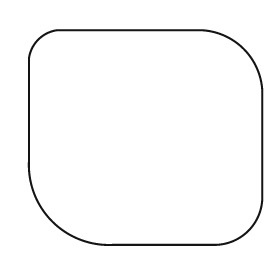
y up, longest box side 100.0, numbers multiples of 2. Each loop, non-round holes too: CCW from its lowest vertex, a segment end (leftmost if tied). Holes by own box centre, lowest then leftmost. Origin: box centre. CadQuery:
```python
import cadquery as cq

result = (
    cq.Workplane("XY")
    .moveTo(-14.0, -46.0)
    .lineTo(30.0, -46.0)
    .threePointArc((44.0, -40.0), (50.0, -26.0))
    .lineTo(50.0, 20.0)
    .threePointArc((42.0, 38.0), (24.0, 46.0))
    .lineTo(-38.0, 46.0)
    .threePointArc((-46.0, 42.0), (-50.0, 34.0))
    .lineTo(-50.0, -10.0)
    .threePointArc((-40.0, -36.0), (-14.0, -46.0))
    .close()
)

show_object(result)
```